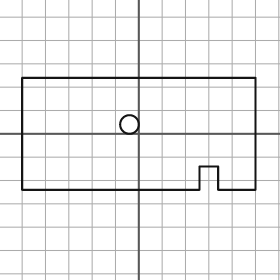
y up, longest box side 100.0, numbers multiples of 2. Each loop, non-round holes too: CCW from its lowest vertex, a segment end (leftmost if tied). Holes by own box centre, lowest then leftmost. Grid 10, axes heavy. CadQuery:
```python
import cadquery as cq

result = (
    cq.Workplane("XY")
    .moveTo(-50.0, -24.0)
    .lineTo(26.0, -24.0)
    .lineTo(26.0, -14.0)
    .lineTo(34.0, -14.0)
    .lineTo(34.0, -24.0)
    .lineTo(50.0, -24.0)
    .lineTo(50.0, 24.0)
    .lineTo(-50.0, 24.0)
    .close()
    .moveTo(-4.0, 4.0)
    .circle(4.0)
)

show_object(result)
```